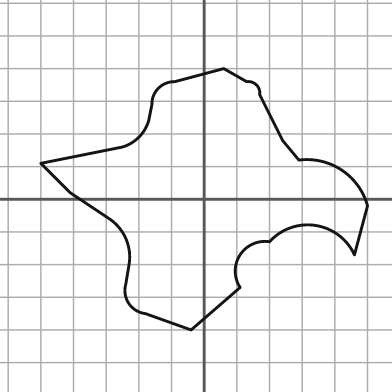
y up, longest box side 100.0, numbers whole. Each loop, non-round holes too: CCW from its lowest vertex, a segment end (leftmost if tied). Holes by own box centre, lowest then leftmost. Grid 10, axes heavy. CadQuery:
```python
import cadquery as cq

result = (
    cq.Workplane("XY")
    .moveTo(-4.0, -40.0)
    .lineTo(11.0, -27.0)
    .threePointArc((11.0, -17.0), (20.0, -13.0))
    .threePointArc((34.0, -8.0), (46.0, -17.0))
    .lineTo(50.0, -2.0)
    .threePointArc((42.0, 9.0), (29.0, 12.0))
    .lineTo(24.0, 18.0)
    .lineTo(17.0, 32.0)
    .threePointArc((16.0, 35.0), (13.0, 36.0))
    .lineTo(6.0, 40.0)
    .lineTo(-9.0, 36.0)
    .threePointArc((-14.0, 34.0), (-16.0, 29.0))
    .lineTo(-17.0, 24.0)
    .threePointArc((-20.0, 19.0), (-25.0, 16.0))
    .lineTo(-50.0, 11.0)
    .lineTo(-41.0, 2.0)
    .lineTo(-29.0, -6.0)
    .threePointArc((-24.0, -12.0), (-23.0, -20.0))
    .lineTo(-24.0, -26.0)
    .threePointArc((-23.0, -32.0), (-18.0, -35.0))
    .close()
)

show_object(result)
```